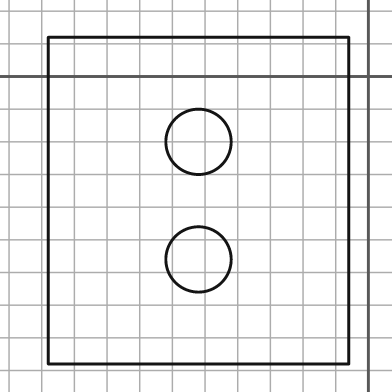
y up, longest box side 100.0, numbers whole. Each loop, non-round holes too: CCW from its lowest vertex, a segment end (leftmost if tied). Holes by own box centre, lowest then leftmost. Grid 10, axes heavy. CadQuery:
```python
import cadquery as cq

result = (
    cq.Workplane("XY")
    .moveTo(-98.0, -88.0)
    .lineTo(-6.0, -88.0)
    .lineTo(-6.0, 12.0)
    .lineTo(-98.0, 12.0)
    .close()
    .moveTo(-52.0, -56.0)
    .circle(10.0)
    .moveTo(-52.0, -20.0)
    .circle(10.0)
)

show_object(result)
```